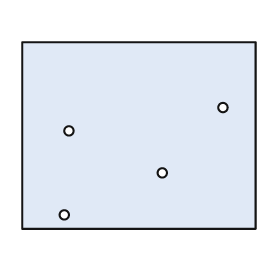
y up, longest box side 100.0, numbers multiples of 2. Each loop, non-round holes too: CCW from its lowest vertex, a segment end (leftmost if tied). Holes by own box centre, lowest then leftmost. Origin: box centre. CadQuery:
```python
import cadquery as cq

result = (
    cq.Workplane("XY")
    .moveTo(-50.0, -40.0)
    .lineTo(50.0, -40.0)
    .lineTo(50.0, 40.0)
    .lineTo(-50.0, 40.0)
    .close()
    .moveTo(-32.0, -34.0)
    .circle(2.0)
    .moveTo(10.0, -16.0)
    .circle(2.0)
    .moveTo(-30.0, 2.0)
    .circle(2.0)
    .moveTo(36.0, 12.0)
    .circle(2.0)
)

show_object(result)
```